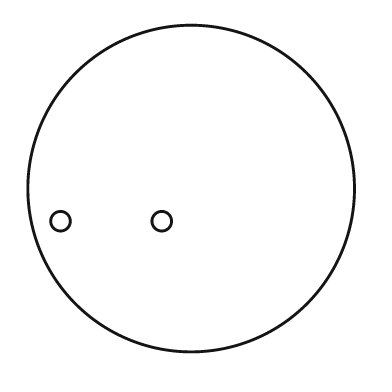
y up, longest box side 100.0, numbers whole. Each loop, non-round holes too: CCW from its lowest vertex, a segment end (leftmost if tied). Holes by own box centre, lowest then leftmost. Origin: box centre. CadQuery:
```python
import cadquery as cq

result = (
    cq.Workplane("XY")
    .moveTo(0.0, 0.0)
    .circle(50.0)
    .moveTo(-40.0, -10.0)
    .circle(3.0)
    .moveTo(-9.0, -10.0)
    .circle(3.0)
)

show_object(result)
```